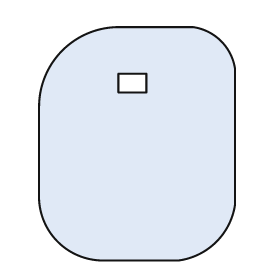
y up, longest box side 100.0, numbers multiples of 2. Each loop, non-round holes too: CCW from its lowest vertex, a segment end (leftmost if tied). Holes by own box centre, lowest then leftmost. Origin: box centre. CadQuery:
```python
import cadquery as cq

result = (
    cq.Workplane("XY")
    .moveTo(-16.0, -50.0)
    .lineTo(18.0, -50.0)
    .threePointArc((34.0, -42.0), (42.0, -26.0))
    .lineTo(42.0, 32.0)
    .threePointArc((36.0, 44.0), (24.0, 50.0))
    .lineTo(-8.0, 50.0)
    .threePointArc((-32.0, 40.0), (-42.0, 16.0))
    .lineTo(-42.0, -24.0)
    .threePointArc((-34.0, -42.0), (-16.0, -50.0))
    .close()
    .moveTo(-8.0, 22.0)
    .lineTo(4.0, 22.0)
    .lineTo(4.0, 30.0)
    .lineTo(-8.0, 30.0)
    .close()
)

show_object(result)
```